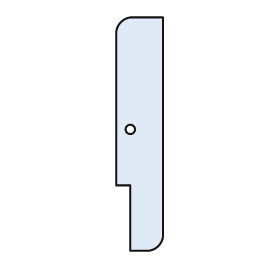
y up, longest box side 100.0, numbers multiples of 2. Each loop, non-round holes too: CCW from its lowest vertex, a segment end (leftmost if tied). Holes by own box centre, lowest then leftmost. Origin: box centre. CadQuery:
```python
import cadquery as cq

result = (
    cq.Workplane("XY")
    .moveTo(-4.0, -50.0)
    .lineTo(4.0, -50.0)
    .threePointArc((8.0, -48.0), (10.0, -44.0))
    .lineTo(10.0, 50.0)
    .lineTo(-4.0, 50.0)
    .threePointArc((-8.0, 48.0), (-10.0, 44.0))
    .lineTo(-10.0, -22.0)
    .lineTo(-4.0, -22.0)
    .close()
    .moveTo(-4.0, 2.0)
    .circle(2.0)
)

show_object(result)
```